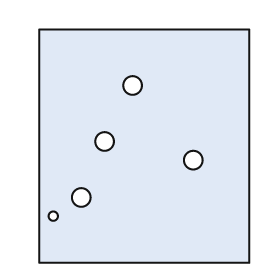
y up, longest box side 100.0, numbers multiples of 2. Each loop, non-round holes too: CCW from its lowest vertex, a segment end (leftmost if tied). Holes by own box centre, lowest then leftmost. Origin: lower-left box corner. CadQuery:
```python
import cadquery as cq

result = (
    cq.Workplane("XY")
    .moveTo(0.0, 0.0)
    .lineTo(90.0, 0.0)
    .lineTo(90.0, 100.0)
    .lineTo(0.0, 100.0)
    .close()
    .moveTo(6.0, 20.0)
    .circle(2.0)
    .moveTo(18.0, 28.0)
    .circle(4.0)
    .moveTo(66.0, 44.0)
    .circle(4.0)
    .moveTo(28.0, 52.0)
    .circle(4.0)
    .moveTo(40.0, 76.0)
    .circle(4.0)
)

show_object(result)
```